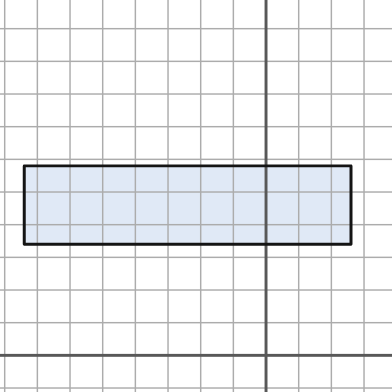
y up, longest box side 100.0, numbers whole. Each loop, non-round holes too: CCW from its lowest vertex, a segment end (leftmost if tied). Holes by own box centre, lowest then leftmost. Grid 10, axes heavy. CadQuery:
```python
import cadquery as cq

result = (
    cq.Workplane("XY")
    .moveTo(-74.0, 34.0)
    .lineTo(26.0, 34.0)
    .lineTo(26.0, 58.0)
    .lineTo(-74.0, 58.0)
    .close()
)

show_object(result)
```